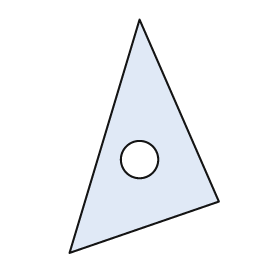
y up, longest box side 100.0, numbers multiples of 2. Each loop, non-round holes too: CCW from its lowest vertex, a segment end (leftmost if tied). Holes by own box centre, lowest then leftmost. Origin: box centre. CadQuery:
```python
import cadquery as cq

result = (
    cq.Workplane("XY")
    .moveTo(-32.0, -50.0)
    .lineTo(32.0, -28.0)
    .lineTo(-2.0, 50.0)
    .close()
    .moveTo(-2.0, -10.0)
    .circle(8.0)
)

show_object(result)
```